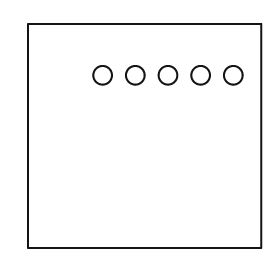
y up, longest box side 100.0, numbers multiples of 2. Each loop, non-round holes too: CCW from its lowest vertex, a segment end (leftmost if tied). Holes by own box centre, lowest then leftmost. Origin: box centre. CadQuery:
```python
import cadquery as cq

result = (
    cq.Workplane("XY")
    .moveTo(-50.0, -48.0)
    .lineTo(50.0, -48.0)
    .lineTo(50.0, 48.0)
    .lineTo(-50.0, 48.0)
    .close()
    .moveTo(-18.0, 26.0)
    .circle(4.0)
    .moveTo(-4.0, 26.0)
    .circle(4.0)
    .moveTo(10.0, 26.0)
    .circle(4.0)
    .moveTo(24.0, 26.0)
    .circle(4.0)
    .moveTo(38.0, 26.0)
    .circle(4.0)
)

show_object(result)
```